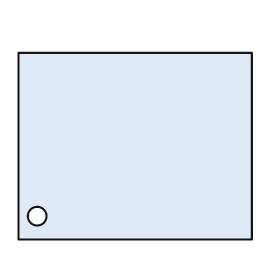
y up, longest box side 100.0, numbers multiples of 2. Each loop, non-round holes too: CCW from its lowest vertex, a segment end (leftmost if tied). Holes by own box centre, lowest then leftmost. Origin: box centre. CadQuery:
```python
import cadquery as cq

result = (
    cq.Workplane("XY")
    .moveTo(-50.0, -40.0)
    .lineTo(50.0, -40.0)
    .lineTo(50.0, 40.0)
    .lineTo(-50.0, 40.0)
    .close()
    .moveTo(-42.0, -30.0)
    .circle(4.0)
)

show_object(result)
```